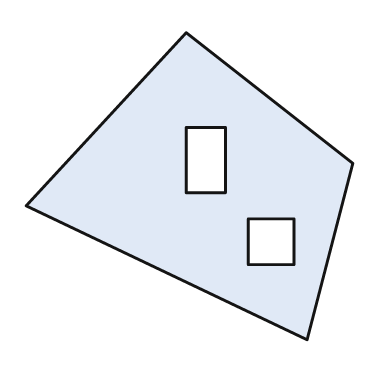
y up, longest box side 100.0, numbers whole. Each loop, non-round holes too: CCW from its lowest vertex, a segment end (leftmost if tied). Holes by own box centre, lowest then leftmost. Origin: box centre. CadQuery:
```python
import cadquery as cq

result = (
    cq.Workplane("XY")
    .moveTo(36.0, -47.0)
    .lineTo(50.0, 7.0)
    .lineTo(-1.0, 47.0)
    .lineTo(-50.0, -6.0)
    .close()
    .moveTo(18.0, -24.0)
    .lineTo(32.0, -24.0)
    .lineTo(32.0, -10.0)
    .lineTo(18.0, -10.0)
    .close()
    .moveTo(-1.0, -2.0)
    .lineTo(11.0, -2.0)
    .lineTo(11.0, 18.0)
    .lineTo(-1.0, 18.0)
    .close()
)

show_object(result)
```